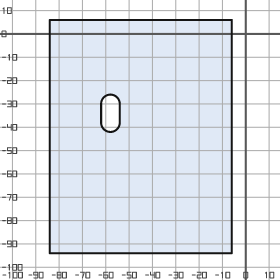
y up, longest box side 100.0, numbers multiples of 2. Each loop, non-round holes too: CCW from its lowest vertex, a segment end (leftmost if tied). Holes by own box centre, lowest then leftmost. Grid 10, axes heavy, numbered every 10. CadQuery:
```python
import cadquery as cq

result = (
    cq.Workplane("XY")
    .moveTo(-84.0, -94.0)
    .lineTo(-6.0, -94.0)
    .lineTo(-6.0, 6.0)
    .lineTo(-84.0, 6.0)
    .close()
    .moveTo(-62.0, -38.0)
    .threePointArc((-58.0, -42.0), (-54.0, -38.0))
    .lineTo(-54.0, -30.0)
    .threePointArc((-58.0, -26.0), (-62.0, -30.0))
    .close()
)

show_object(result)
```